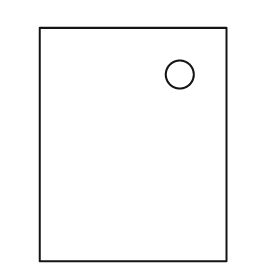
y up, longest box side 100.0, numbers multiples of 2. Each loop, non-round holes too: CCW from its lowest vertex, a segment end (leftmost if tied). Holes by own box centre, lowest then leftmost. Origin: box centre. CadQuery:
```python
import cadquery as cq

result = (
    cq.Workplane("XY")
    .moveTo(-40.0, -50.0)
    .lineTo(40.0, -50.0)
    .lineTo(40.0, 50.0)
    .lineTo(-40.0, 50.0)
    .close()
    .moveTo(20.0, 30.0)
    .circle(6.0)
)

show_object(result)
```